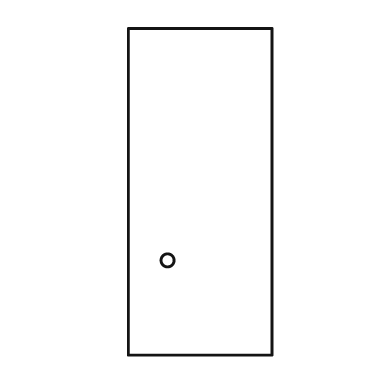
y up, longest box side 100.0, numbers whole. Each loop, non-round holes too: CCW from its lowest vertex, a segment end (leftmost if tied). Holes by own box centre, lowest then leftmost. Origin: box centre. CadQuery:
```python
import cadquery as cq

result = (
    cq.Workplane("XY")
    .moveTo(-22.0, -50.0)
    .lineTo(22.0, -50.0)
    .lineTo(22.0, 50.0)
    .lineTo(-22.0, 50.0)
    .close()
    .moveTo(-10.0, -21.0)
    .circle(2.0)
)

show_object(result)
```